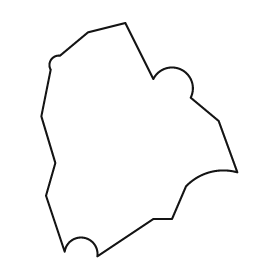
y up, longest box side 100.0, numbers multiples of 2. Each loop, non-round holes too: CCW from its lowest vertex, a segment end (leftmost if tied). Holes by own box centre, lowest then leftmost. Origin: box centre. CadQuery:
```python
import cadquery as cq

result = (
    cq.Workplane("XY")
    .moveTo(-18.0, -50.0)
    .lineTo(6.0, -34.0)
    .lineTo(14.0, -34.0)
    .lineTo(20.0, -20.0)
    .threePointArc((30.0, -14.0), (42.0, -14.0))
    .lineTo(34.0, 8.0)
    .lineTo(22.0, 18.0)
    .threePointArc((18.0, 30.0), (6.0, 26.0))
    .lineTo(-6.0, 50.0)
    .lineTo(-22.0, 46.0)
    .lineTo(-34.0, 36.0)
    .threePointArc((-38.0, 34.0), (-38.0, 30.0))
    .lineTo(-42.0, 10.0)
    .lineTo(-36.0, -10.0)
    .lineTo(-40.0, -24.0)
    .lineTo(-32.0, -48.0)
    .threePointArc((-24.0, -42.0), (-18.0, -50.0))
    .close()
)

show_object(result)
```